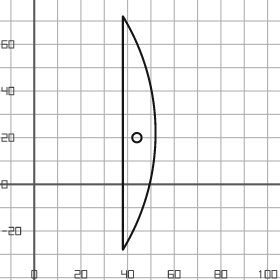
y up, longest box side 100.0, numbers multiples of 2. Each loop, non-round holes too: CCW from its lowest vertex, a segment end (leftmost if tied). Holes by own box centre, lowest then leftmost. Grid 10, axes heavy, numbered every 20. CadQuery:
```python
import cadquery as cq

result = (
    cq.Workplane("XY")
    .moveTo(38.0, -28.0)
    .threePointArc((52.0, 22.0), (38.0, 72.0))
    .close()
    .moveTo(44.0, 20.0)
    .circle(2.0)
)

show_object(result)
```